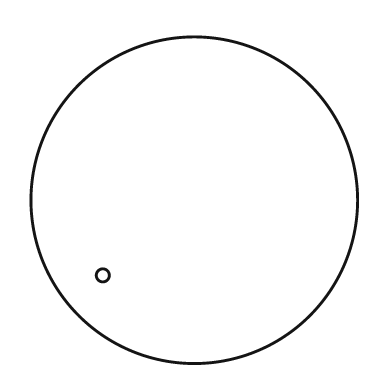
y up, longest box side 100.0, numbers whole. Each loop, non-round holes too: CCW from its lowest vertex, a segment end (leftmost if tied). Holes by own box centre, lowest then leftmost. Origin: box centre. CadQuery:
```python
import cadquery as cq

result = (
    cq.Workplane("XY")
    .moveTo(0.0, 0.0)
    .circle(50.0)
    .moveTo(-28.0, -23.0)
    .circle(2.0)
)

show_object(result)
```